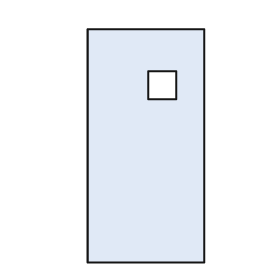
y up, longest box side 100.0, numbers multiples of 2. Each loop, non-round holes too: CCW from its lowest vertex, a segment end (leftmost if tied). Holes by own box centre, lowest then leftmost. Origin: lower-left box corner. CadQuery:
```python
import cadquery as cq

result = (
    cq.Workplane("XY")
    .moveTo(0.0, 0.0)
    .lineTo(50.0, 0.0)
    .lineTo(50.0, 100.0)
    .lineTo(0.0, 100.0)
    .close()
    .moveTo(26.0, 70.0)
    .lineTo(38.0, 70.0)
    .lineTo(38.0, 82.0)
    .lineTo(26.0, 82.0)
    .close()
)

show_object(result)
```